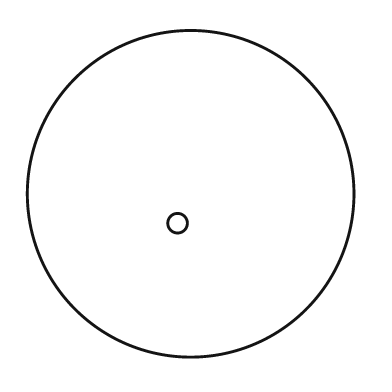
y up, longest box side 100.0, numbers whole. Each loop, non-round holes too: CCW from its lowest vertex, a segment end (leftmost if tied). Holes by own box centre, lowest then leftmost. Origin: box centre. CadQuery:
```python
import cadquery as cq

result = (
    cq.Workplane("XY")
    .moveTo(0.0, 0.0)
    .circle(50.0)
    .moveTo(-4.0, -9.0)
    .circle(3.0)
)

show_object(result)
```